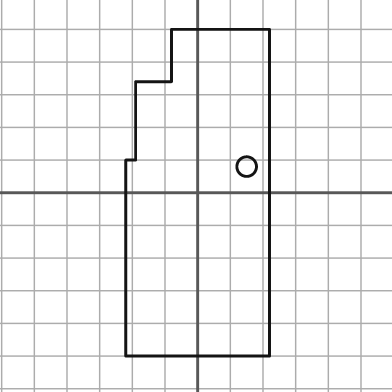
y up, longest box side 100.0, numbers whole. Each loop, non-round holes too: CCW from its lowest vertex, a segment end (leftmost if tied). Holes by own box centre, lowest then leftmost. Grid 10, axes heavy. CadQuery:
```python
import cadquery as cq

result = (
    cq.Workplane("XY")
    .moveTo(-22.0, -50.0)
    .lineTo(22.0, -50.0)
    .lineTo(22.0, 50.0)
    .lineTo(-8.0, 50.0)
    .lineTo(-8.0, 34.0)
    .lineTo(-19.0, 34.0)
    .lineTo(-19.0, 10.0)
    .lineTo(-22.0, 10.0)
    .close()
    .moveTo(15.0, 8.0)
    .circle(3.0)
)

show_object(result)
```